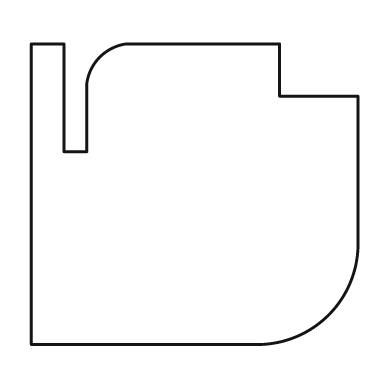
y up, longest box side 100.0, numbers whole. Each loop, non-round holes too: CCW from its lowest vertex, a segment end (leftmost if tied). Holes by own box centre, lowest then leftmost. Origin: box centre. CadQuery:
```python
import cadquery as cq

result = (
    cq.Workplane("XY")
    .moveTo(-50.0, -46.0)
    .lineTo(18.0, -46.0)
    .threePointArc((41.0, -37.0), (50.0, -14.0))
    .lineTo(50.0, 30.0)
    .lineTo(26.0, 30.0)
    .lineTo(26.0, 46.0)
    .lineTo(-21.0, 46.0)
    .threePointArc((-29.0, 42.0), (-33.0, 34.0))
    .lineTo(-33.0, 13.0)
    .lineTo(-40.0, 13.0)
    .lineTo(-40.0, 46.0)
    .lineTo(-50.0, 46.0)
    .close()
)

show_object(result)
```